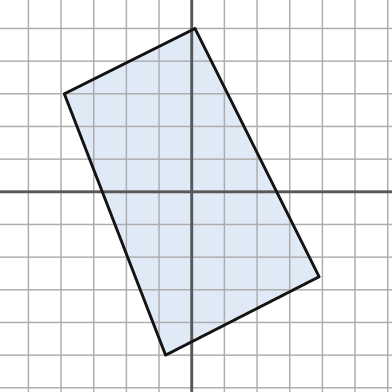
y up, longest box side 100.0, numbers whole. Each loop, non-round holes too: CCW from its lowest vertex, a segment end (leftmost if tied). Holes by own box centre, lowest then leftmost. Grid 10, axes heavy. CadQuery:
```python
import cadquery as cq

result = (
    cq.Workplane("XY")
    .moveTo(-8.0, -50.0)
    .lineTo(39.0, -26.0)
    .lineTo(1.0, 50.0)
    .lineTo(-39.0, 30.0)
    .close()
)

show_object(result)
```